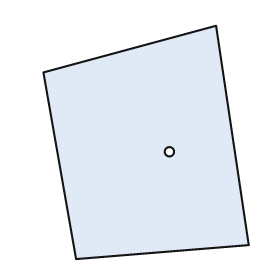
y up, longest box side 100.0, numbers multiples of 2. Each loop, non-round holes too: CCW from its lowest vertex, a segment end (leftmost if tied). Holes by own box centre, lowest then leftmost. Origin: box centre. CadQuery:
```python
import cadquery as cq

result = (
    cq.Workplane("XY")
    .moveTo(-30.0, -50.0)
    .lineTo(44.0, -44.0)
    .lineTo(30.0, 50.0)
    .lineTo(-44.0, 30.0)
    .close()
    .moveTo(10.0, -4.0)
    .circle(2.0)
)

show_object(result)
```